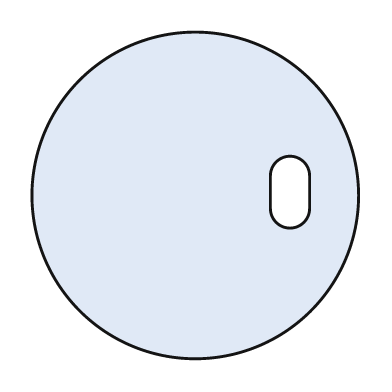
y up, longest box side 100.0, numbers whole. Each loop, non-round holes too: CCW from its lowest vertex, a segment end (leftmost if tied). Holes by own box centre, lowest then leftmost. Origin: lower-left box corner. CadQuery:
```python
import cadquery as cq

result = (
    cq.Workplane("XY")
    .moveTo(50.0, 50.0)
    .circle(50.0)
    .moveTo(73.0, 46.0)
    .threePointArc((79.0, 40.0), (85.0, 46.0))
    .lineTo(85.0, 56.0)
    .threePointArc((79.0, 62.0), (73.0, 56.0))
    .close()
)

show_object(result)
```